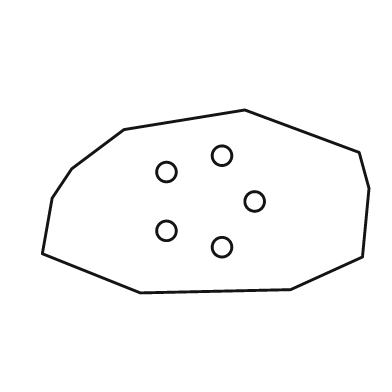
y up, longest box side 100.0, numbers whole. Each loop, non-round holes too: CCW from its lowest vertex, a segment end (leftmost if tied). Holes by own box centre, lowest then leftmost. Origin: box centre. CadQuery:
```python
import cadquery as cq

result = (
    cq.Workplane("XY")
    .moveTo(-20.0, -28.0)
    .lineTo(26.0, -27.0)
    .lineTo(48.0, -17.0)
    .lineTo(50.0, 4.0)
    .lineTo(47.0, 15.0)
    .lineTo(12.0, 28.0)
    .lineTo(-25.0, 22.0)
    .lineTo(-41.0, 10.0)
    .lineTo(-47.0, 1.0)
    .lineTo(-50.0, -16.0)
    .close()
    .moveTo(5.0, -14.0)
    .circle(3.0)
    .moveTo(-12.0, -9.0)
    .circle(3.0)
    .moveTo(15.0, 0.0)
    .circle(3.0)
    .moveTo(-12.0, 9.0)
    .circle(3.0)
    .moveTo(5.0, 14.0)
    .circle(3.0)
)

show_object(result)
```